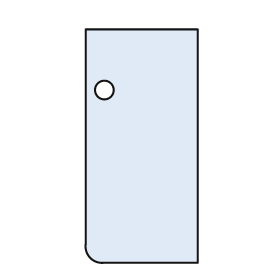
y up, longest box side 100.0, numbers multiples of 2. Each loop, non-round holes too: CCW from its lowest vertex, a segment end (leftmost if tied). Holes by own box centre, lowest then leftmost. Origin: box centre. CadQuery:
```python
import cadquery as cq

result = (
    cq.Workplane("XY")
    .moveTo(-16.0, -50.0)
    .lineTo(24.0, -50.0)
    .lineTo(24.0, 50.0)
    .lineTo(-24.0, 50.0)
    .lineTo(-24.0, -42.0)
    .threePointArc((-22.0, -48.0), (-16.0, -50.0))
    .close()
    .moveTo(-16.0, 24.0)
    .circle(4.0)
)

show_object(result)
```